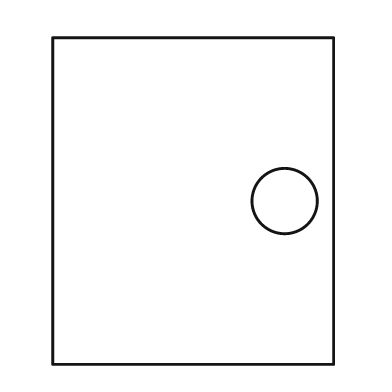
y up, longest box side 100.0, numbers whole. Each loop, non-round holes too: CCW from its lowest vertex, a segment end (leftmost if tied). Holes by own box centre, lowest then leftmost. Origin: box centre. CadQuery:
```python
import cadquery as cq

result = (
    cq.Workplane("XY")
    .moveTo(-43.0, -50.0)
    .lineTo(43.0, -50.0)
    .lineTo(43.0, 50.0)
    .lineTo(-43.0, 50.0)
    .close()
    .moveTo(28.0, 0.0)
    .circle(10.0)
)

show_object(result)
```